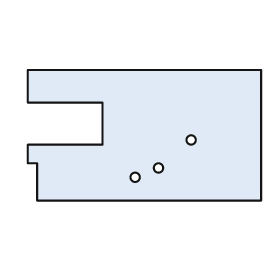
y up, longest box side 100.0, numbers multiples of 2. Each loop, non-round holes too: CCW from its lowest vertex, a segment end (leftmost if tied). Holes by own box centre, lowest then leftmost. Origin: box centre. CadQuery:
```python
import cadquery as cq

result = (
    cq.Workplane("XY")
    .moveTo(-46.0, -28.0)
    .lineTo(50.0, -28.0)
    .lineTo(50.0, 28.0)
    .lineTo(-50.0, 28.0)
    .lineTo(-50.0, 14.0)
    .lineTo(-18.0, 14.0)
    .lineTo(-18.0, -4.0)
    .lineTo(-50.0, -4.0)
    .lineTo(-50.0, -12.0)
    .lineTo(-46.0, -12.0)
    .close()
    .moveTo(-4.0, -18.0)
    .circle(2.0)
    .moveTo(6.0, -14.0)
    .circle(2.0)
    .moveTo(20.0, -2.0)
    .circle(2.0)
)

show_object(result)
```